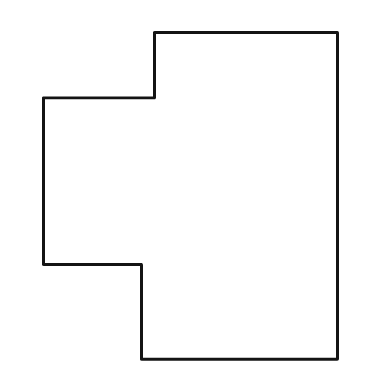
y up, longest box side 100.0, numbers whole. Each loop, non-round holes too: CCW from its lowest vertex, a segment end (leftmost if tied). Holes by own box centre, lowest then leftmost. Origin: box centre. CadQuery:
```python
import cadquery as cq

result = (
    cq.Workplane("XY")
    .moveTo(-15.0, -50.0)
    .lineTo(45.0, -50.0)
    .lineTo(45.0, 50.0)
    .lineTo(-11.0, 50.0)
    .lineTo(-11.0, 30.0)
    .lineTo(-45.0, 30.0)
    .lineTo(-45.0, -21.0)
    .lineTo(-15.0, -21.0)
    .close()
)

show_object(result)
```